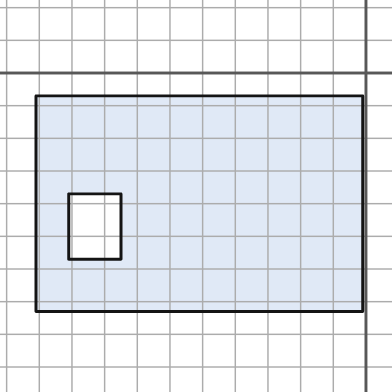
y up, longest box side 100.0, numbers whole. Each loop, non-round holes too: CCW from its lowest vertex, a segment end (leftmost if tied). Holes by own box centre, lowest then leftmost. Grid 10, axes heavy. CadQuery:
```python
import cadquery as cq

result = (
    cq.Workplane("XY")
    .moveTo(-101.0, -73.0)
    .lineTo(-1.0, -73.0)
    .lineTo(-1.0, -7.0)
    .lineTo(-101.0, -7.0)
    .close()
    .moveTo(-91.0, -57.0)
    .lineTo(-75.0, -57.0)
    .lineTo(-75.0, -37.0)
    .lineTo(-91.0, -37.0)
    .close()
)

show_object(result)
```